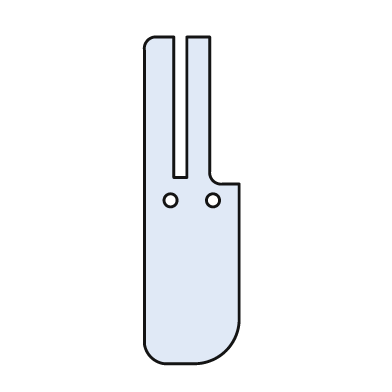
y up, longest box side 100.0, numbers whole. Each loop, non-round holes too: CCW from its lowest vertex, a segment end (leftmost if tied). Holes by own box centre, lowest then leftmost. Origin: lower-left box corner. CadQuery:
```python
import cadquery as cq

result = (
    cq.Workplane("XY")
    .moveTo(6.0, 0.0)
    .lineTo(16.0, 0.0)
    .threePointArc((25.0, 4.0), (29.0, 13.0))
    .lineTo(29.0, 55.0)
    .lineTo(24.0, 55.0)
    .threePointArc((21.0, 56.0), (20.0, 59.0))
    .lineTo(20.0, 100.0)
    .lineTo(13.0, 100.0)
    .lineTo(13.0, 57.0)
    .lineTo(9.0, 57.0)
    .lineTo(9.0, 100.0)
    .lineTo(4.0, 100.0)
    .threePointArc((1.0, 99.0), (0.0, 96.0))
    .lineTo(0.0, 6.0)
    .threePointArc((2.0, 2.0), (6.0, 0.0))
    .close()
    .moveTo(8.0, 50.0)
    .circle(2.0)
    .moveTo(21.0, 50.0)
    .circle(2.0)
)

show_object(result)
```